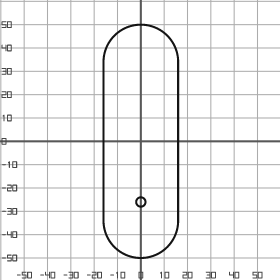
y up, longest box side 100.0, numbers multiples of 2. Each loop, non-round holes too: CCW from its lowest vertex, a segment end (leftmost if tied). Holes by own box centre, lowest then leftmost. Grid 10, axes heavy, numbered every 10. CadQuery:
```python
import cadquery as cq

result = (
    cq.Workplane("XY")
    .moveTo(-16.0, -34.0)
    .threePointArc((0.0, -50.0), (16.0, -34.0))
    .lineTo(16.0, 34.0)
    .threePointArc((0.0, 50.0), (-16.0, 34.0))
    .close()
    .moveTo(0.0, -26.0)
    .circle(2.0)
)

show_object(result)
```